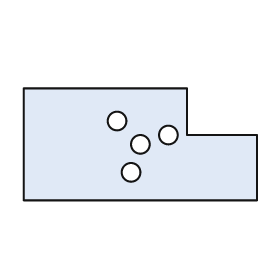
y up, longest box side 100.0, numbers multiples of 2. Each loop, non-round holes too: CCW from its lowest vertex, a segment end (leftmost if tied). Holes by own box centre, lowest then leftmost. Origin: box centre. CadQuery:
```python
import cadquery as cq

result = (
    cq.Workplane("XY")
    .moveTo(-50.0, -24.0)
    .lineTo(50.0, -24.0)
    .lineTo(50.0, 4.0)
    .lineTo(20.0, 4.0)
    .lineTo(20.0, 24.0)
    .lineTo(-50.0, 24.0)
    .close()
    .moveTo(-4.0, -12.0)
    .circle(4.0)
    .moveTo(0.0, 0.0)
    .circle(4.0)
    .moveTo(12.0, 4.0)
    .circle(4.0)
    .moveTo(-10.0, 10.0)
    .circle(4.0)
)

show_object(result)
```